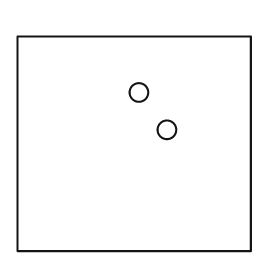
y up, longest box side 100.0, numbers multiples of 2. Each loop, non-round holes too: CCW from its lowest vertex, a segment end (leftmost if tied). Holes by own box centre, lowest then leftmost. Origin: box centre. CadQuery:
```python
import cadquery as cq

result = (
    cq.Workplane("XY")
    .moveTo(-50.0, -46.0)
    .lineTo(50.0, -46.0)
    .lineTo(50.0, 46.0)
    .lineTo(-50.0, 46.0)
    .close()
    .moveTo(14.0, 6.0)
    .circle(4.0)
    .moveTo(2.0, 22.0)
    .circle(4.0)
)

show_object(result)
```